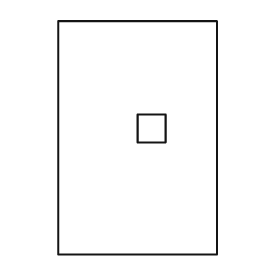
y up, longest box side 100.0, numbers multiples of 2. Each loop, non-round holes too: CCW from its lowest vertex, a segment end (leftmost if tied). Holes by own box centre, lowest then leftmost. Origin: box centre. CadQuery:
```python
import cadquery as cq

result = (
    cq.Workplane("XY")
    .moveTo(-34.0, -50.0)
    .lineTo(34.0, -50.0)
    .lineTo(34.0, 50.0)
    .lineTo(-34.0, 50.0)
    .close()
    .moveTo(0.0, -2.0)
    .lineTo(12.0, -2.0)
    .lineTo(12.0, 10.0)
    .lineTo(0.0, 10.0)
    .close()
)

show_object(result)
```